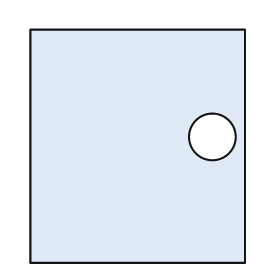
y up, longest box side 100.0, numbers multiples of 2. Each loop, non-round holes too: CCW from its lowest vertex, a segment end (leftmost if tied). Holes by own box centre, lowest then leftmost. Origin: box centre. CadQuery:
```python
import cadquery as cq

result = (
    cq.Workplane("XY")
    .moveTo(-46.0, -50.0)
    .lineTo(46.0, -50.0)
    .lineTo(46.0, 50.0)
    .lineTo(-46.0, 50.0)
    .close()
    .moveTo(32.0, 4.0)
    .circle(10.0)
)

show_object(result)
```